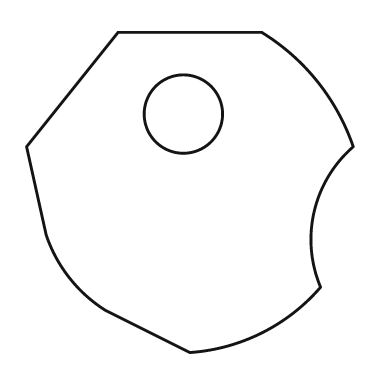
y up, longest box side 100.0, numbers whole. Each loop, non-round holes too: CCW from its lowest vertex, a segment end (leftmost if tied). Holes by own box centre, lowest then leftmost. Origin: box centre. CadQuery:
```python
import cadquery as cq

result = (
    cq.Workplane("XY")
    .moveTo(0.0, -49.0)
    .threePointArc((22.0, -43.0), (40.0, -29.0))
    .threePointArc((38.0, -6.0), (50.0, 14.0))
    .threePointArc((39.0, 34.0), (22.0, 49.0))
    .lineTo(-22.0, 49.0)
    .lineTo(-50.0, 14.0)
    .lineTo(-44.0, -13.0)
    .threePointArc((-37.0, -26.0), (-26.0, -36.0))
    .close()
    .moveTo(-2.0, 24.0)
    .circle(12.0)
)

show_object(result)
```